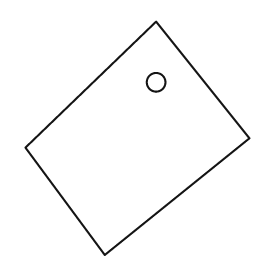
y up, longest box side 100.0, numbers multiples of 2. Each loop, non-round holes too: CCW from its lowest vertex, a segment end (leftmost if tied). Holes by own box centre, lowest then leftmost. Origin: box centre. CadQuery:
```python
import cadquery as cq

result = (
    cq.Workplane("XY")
    .moveTo(-14.0, -50.0)
    .lineTo(48.0, 0.0)
    .lineTo(8.0, 50.0)
    .lineTo(-48.0, -4.0)
    .close()
    .moveTo(8.0, 24.0)
    .circle(4.0)
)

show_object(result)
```